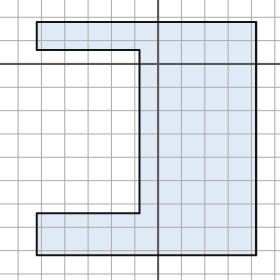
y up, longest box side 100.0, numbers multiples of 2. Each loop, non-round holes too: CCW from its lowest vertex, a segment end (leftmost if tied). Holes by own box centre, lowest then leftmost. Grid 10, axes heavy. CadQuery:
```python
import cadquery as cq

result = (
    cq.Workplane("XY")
    .moveTo(-52.0, -82.0)
    .lineTo(42.0, -82.0)
    .lineTo(42.0, 18.0)
    .lineTo(-52.0, 18.0)
    .lineTo(-52.0, 6.0)
    .lineTo(-8.0, 6.0)
    .lineTo(-8.0, -64.0)
    .lineTo(-52.0, -64.0)
    .close()
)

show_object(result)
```